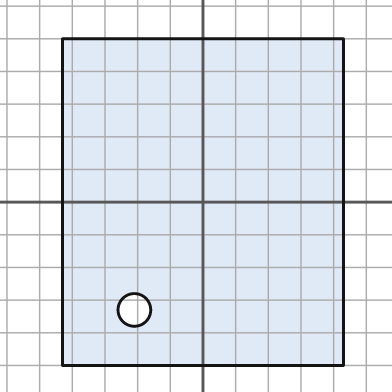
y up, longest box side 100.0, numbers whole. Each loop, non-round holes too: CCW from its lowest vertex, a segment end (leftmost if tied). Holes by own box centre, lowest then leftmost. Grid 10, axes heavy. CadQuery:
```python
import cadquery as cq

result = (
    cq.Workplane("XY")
    .moveTo(-43.0, -50.0)
    .lineTo(43.0, -50.0)
    .lineTo(43.0, 50.0)
    .lineTo(-43.0, 50.0)
    .close()
    .moveTo(-21.0, -33.0)
    .circle(5.0)
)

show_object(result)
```